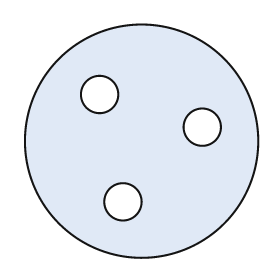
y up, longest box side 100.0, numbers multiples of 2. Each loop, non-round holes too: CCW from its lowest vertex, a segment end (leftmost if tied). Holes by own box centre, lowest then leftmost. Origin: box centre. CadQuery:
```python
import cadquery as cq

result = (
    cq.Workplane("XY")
    .moveTo(0.0, 0.0)
    .circle(50.0)
    .moveTo(-8.0, -26.0)
    .circle(8.0)
    .moveTo(26.0, 6.0)
    .circle(8.0)
    .moveTo(-18.0, 20.0)
    .circle(8.0)
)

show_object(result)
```